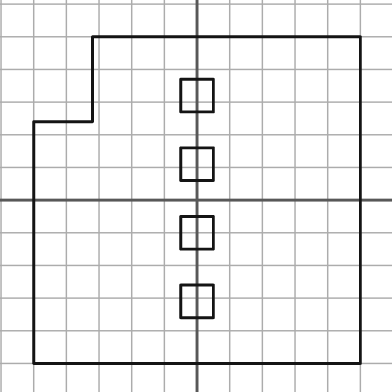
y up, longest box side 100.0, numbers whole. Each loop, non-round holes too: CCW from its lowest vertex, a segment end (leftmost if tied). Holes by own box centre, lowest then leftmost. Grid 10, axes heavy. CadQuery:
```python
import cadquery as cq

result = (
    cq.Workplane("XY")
    .moveTo(-50.0, -50.0)
    .lineTo(50.0, -50.0)
    .lineTo(50.0, 50.0)
    .lineTo(-32.0, 50.0)
    .lineTo(-32.0, 24.0)
    .lineTo(-50.0, 24.0)
    .close()
    .moveTo(-5.0, -36.0)
    .lineTo(5.0, -36.0)
    .lineTo(5.0, -26.0)
    .lineTo(-5.0, -26.0)
    .close()
    .moveTo(-5.0, -15.0)
    .lineTo(5.0, -15.0)
    .lineTo(5.0, -5.0)
    .lineTo(-5.0, -5.0)
    .close()
    .moveTo(-5.0, 6.0)
    .lineTo(5.0, 6.0)
    .lineTo(5.0, 16.0)
    .lineTo(-5.0, 16.0)
    .close()
    .moveTo(-5.0, 27.0)
    .lineTo(5.0, 27.0)
    .lineTo(5.0, 37.0)
    .lineTo(-5.0, 37.0)
    .close()
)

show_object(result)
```